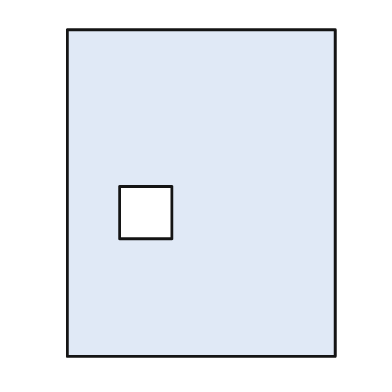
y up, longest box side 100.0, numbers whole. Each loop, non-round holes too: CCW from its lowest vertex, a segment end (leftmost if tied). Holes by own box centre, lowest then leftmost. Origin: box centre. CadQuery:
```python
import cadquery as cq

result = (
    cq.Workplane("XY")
    .moveTo(-41.0, -50.0)
    .lineTo(41.0, -50.0)
    .lineTo(41.0, 50.0)
    .lineTo(-41.0, 50.0)
    .close()
    .moveTo(-25.0, -14.0)
    .lineTo(-9.0, -14.0)
    .lineTo(-9.0, 2.0)
    .lineTo(-25.0, 2.0)
    .close()
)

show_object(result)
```